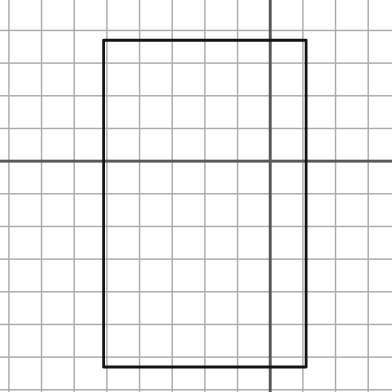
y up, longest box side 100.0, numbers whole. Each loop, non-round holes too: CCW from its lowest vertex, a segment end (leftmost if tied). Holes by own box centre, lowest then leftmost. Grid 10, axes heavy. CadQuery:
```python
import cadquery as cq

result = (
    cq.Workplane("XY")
    .moveTo(-51.0, -63.0)
    .lineTo(11.0, -63.0)
    .lineTo(11.0, 37.0)
    .lineTo(-51.0, 37.0)
    .close()
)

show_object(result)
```